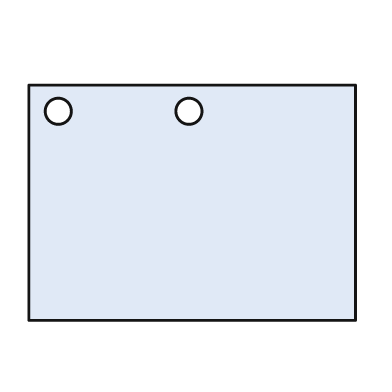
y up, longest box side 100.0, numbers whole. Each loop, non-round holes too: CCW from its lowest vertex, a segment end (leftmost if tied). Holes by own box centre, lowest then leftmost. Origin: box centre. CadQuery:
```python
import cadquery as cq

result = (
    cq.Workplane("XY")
    .moveTo(-50.0, -36.0)
    .lineTo(50.0, -36.0)
    .lineTo(50.0, 36.0)
    .lineTo(-50.0, 36.0)
    .close()
    .moveTo(-41.0, 28.0)
    .circle(4.0)
    .moveTo(-1.0, 28.0)
    .circle(4.0)
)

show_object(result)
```